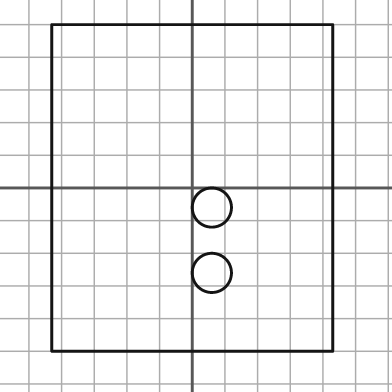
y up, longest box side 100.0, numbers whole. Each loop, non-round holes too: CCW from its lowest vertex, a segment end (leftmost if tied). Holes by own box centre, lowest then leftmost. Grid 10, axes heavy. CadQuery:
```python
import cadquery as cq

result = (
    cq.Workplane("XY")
    .moveTo(-43.0, -50.0)
    .lineTo(43.0, -50.0)
    .lineTo(43.0, 50.0)
    .lineTo(-43.0, 50.0)
    .close()
    .moveTo(6.0, -26.0)
    .circle(6.0)
    .moveTo(6.0, -6.0)
    .circle(6.0)
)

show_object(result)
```